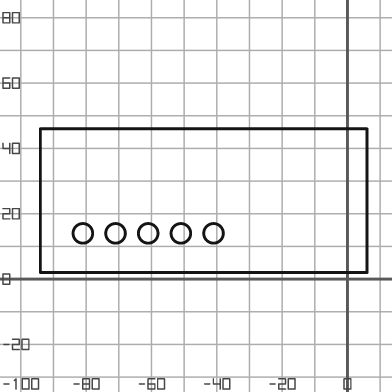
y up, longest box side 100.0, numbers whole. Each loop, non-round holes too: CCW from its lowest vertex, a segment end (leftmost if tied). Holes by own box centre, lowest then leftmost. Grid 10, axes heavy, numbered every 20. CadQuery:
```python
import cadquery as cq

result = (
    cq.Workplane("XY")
    .moveTo(-94.0, 2.0)
    .lineTo(6.0, 2.0)
    .lineTo(6.0, 46.0)
    .lineTo(-94.0, 46.0)
    .close()
    .moveTo(-81.0, 14.0)
    .circle(3.0)
    .moveTo(-71.0, 14.0)
    .circle(3.0)
    .moveTo(-61.0, 14.0)
    .circle(3.0)
    .moveTo(-51.0, 14.0)
    .circle(3.0)
    .moveTo(-41.0, 14.0)
    .circle(3.0)
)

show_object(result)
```